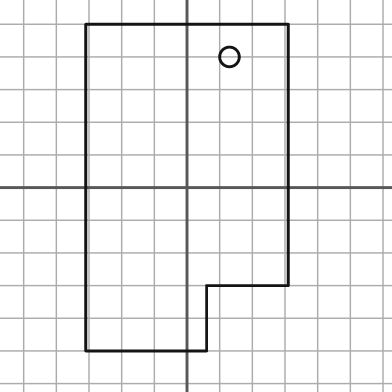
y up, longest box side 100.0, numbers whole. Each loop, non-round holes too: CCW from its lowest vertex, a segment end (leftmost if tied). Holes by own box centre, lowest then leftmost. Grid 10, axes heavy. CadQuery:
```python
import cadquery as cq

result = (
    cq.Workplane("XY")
    .moveTo(-31.0, -50.0)
    .lineTo(6.0, -50.0)
    .lineTo(6.0, -30.0)
    .lineTo(31.0, -30.0)
    .lineTo(31.0, 50.0)
    .lineTo(-31.0, 50.0)
    .close()
    .moveTo(13.0, 40.0)
    .circle(3.0)
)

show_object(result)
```